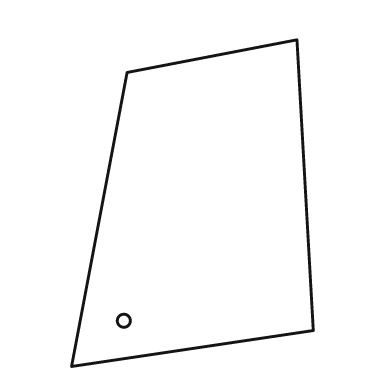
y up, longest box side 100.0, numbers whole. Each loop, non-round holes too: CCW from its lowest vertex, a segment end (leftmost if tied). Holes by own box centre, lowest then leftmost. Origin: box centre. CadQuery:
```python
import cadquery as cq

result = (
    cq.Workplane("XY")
    .moveTo(-37.0, -50.0)
    .lineTo(37.0, -39.0)
    .lineTo(32.0, 50.0)
    .lineTo(-20.0, 40.0)
    .close()
    .moveTo(-21.0, -36.0)
    .circle(2.0)
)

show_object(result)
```